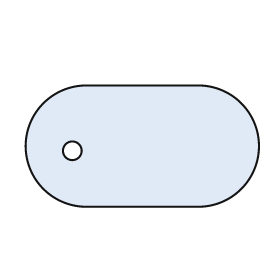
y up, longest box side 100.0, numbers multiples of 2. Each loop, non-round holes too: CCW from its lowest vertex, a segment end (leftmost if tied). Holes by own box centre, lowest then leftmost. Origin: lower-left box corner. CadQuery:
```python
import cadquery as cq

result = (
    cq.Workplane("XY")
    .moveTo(26.0, 0.0)
    .lineTo(74.0, 0.0)
    .threePointArc((100.0, 26.0), (74.0, 52.0))
    .lineTo(26.0, 52.0)
    .threePointArc((0.0, 26.0), (26.0, 0.0))
    .close()
    .moveTo(20.0, 24.0)
    .circle(4.0)
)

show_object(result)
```